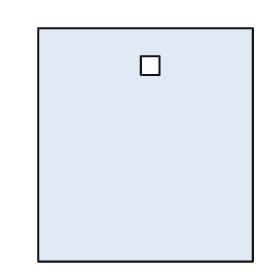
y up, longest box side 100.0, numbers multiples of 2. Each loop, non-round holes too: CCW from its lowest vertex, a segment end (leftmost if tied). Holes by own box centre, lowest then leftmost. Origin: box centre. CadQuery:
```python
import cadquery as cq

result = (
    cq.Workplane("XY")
    .moveTo(-46.0, -50.0)
    .lineTo(46.0, -50.0)
    .lineTo(46.0, 50.0)
    .lineTo(-46.0, 50.0)
    .close()
    .moveTo(-2.0, 30.0)
    .lineTo(6.0, 30.0)
    .lineTo(6.0, 38.0)
    .lineTo(-2.0, 38.0)
    .close()
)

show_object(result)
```